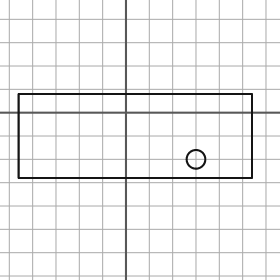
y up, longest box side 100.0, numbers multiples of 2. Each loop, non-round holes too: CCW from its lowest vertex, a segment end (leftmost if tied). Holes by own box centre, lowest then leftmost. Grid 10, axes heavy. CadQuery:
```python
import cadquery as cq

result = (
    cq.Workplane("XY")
    .moveTo(-46.0, -28.0)
    .lineTo(54.0, -28.0)
    .lineTo(54.0, 8.0)
    .lineTo(-46.0, 8.0)
    .close()
    .moveTo(30.0, -20.0)
    .circle(4.0)
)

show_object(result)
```